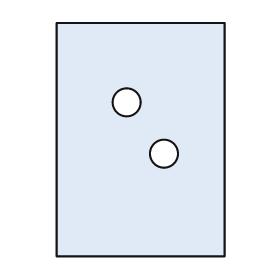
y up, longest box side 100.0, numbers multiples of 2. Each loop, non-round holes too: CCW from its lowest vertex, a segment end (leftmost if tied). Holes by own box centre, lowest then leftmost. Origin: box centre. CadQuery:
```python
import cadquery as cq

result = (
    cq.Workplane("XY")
    .moveTo(-36.0, -50.0)
    .lineTo(36.0, -50.0)
    .lineTo(36.0, 50.0)
    .lineTo(-36.0, 50.0)
    .close()
    .moveTo(10.0, -6.0)
    .circle(6.0)
    .moveTo(-6.0, 16.0)
    .circle(6.0)
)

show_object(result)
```